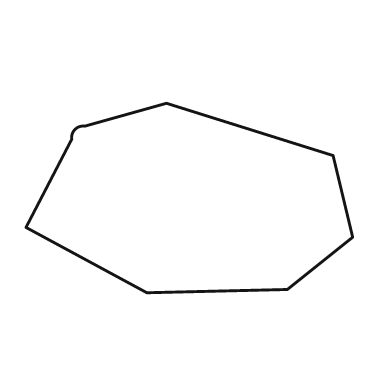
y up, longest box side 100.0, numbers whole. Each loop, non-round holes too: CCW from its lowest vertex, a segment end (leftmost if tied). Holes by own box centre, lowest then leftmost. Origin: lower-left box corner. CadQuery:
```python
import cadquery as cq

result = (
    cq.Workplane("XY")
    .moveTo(37.0, 0.0)
    .lineTo(80.0, 1.0)
    .lineTo(100.0, 17.0)
    .lineTo(94.0, 42.0)
    .lineTo(43.0, 58.0)
    .lineTo(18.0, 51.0)
    .threePointArc((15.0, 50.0), (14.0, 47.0))
    .lineTo(0.0, 20.0)
    .close()
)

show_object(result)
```